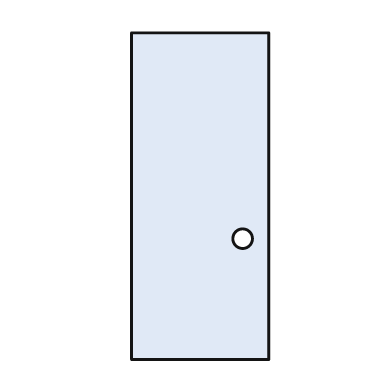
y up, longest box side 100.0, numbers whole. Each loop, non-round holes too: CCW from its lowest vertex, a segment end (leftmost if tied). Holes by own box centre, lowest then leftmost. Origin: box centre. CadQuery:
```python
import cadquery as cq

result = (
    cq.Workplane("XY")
    .moveTo(-21.0, -50.0)
    .lineTo(21.0, -50.0)
    .lineTo(21.0, 50.0)
    .lineTo(-21.0, 50.0)
    .close()
    .moveTo(13.0, -13.0)
    .circle(3.0)
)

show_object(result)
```